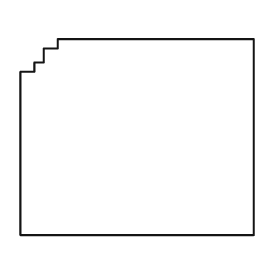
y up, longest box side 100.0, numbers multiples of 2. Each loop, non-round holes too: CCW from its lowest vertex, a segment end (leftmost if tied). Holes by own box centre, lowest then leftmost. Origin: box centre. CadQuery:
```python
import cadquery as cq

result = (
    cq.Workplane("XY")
    .moveTo(-50.0, -42.0)
    .lineTo(50.0, -42.0)
    .lineTo(50.0, 42.0)
    .lineTo(-34.0, 42.0)
    .lineTo(-34.0, 38.0)
    .lineTo(-40.0, 38.0)
    .lineTo(-40.0, 32.0)
    .lineTo(-44.0, 32.0)
    .lineTo(-44.0, 28.0)
    .lineTo(-50.0, 28.0)
    .close()
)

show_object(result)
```